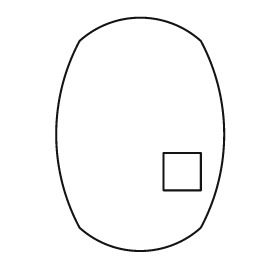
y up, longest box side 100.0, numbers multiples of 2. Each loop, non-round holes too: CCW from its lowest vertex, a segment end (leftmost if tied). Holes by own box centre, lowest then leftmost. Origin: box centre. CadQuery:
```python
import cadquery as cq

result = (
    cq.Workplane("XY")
    .moveTo(-26.0, -40.0)
    .threePointArc((0.0, -50.0), (26.0, -40.0))
    .threePointArc((36.0, 0.0), (26.0, 40.0))
    .threePointArc((0.0, 50.0), (-26.0, 40.0))
    .threePointArc((-36.0, 0.0), (-26.0, -40.0))
    .close()
    .moveTo(10.0, -24.0)
    .lineTo(26.0, -24.0)
    .lineTo(26.0, -8.0)
    .lineTo(10.0, -8.0)
    .close()
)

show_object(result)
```